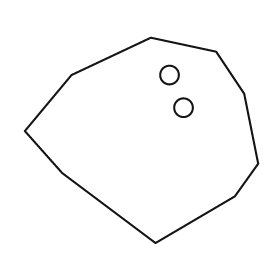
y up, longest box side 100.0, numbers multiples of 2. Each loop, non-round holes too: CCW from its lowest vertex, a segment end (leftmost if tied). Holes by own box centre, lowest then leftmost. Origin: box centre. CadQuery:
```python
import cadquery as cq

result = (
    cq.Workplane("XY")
    .moveTo(6.0, -44.0)
    .lineTo(40.0, -24.0)
    .lineTo(50.0, -10.0)
    .lineTo(44.0, 20.0)
    .lineTo(32.0, 38.0)
    .lineTo(4.0, 44.0)
    .lineTo(-30.0, 28.0)
    .lineTo(-50.0, 4.0)
    .lineTo(-34.0, -14.0)
    .close()
    .moveTo(18.0, 14.0)
    .circle(4.0)
    .moveTo(12.0, 28.0)
    .circle(4.0)
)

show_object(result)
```